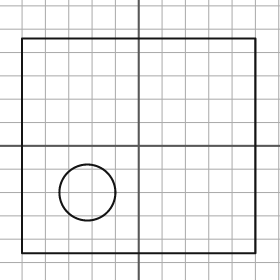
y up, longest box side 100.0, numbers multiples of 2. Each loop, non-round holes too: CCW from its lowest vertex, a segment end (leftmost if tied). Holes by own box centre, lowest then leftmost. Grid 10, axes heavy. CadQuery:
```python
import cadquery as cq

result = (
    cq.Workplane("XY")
    .moveTo(-50.0, -46.0)
    .lineTo(50.0, -46.0)
    .lineTo(50.0, 46.0)
    .lineTo(-50.0, 46.0)
    .close()
    .moveTo(-22.0, -20.0)
    .circle(12.0)
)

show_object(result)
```